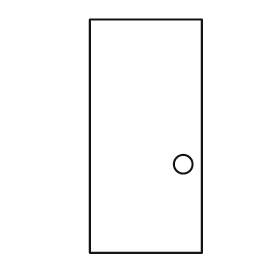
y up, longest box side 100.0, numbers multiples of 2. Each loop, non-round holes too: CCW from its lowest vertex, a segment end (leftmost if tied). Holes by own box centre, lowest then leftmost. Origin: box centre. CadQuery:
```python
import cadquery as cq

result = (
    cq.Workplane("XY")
    .moveTo(-24.0, -50.0)
    .lineTo(24.0, -50.0)
    .lineTo(24.0, 50.0)
    .lineTo(-24.0, 50.0)
    .close()
    .moveTo(16.0, -12.0)
    .circle(4.0)
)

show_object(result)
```